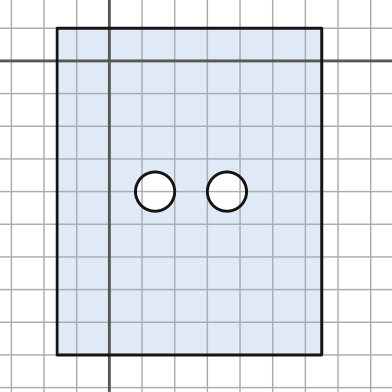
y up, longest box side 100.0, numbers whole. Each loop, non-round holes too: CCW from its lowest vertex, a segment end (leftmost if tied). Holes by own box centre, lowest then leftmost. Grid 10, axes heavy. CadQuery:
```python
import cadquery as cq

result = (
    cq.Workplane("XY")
    .moveTo(-16.0, -90.0)
    .lineTo(65.0, -90.0)
    .lineTo(65.0, 10.0)
    .lineTo(-16.0, 10.0)
    .close()
    .moveTo(14.0, -40.0)
    .circle(6.0)
    .moveTo(36.0, -40.0)
    .circle(6.0)
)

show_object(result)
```